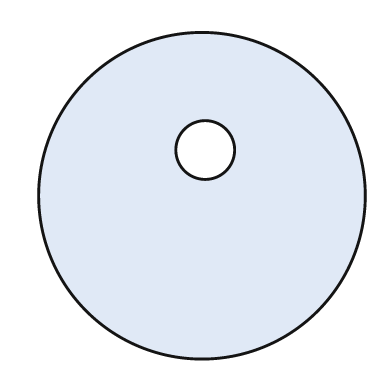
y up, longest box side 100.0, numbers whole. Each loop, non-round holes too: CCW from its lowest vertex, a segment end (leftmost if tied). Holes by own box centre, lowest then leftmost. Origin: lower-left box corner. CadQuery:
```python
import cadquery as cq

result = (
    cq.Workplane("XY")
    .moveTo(50.0, 50.0)
    .circle(50.0)
    .moveTo(51.0, 64.0)
    .circle(9.0)
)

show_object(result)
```